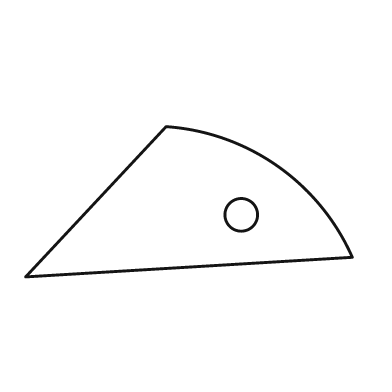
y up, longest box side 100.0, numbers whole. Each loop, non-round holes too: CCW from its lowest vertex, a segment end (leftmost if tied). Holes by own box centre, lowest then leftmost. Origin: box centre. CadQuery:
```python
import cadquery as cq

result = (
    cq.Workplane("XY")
    .moveTo(-50.0, -23.0)
    .lineTo(50.0, -17.0)
    .threePointArc((27.0, 11.0), (-7.0, 23.0))
    .close()
    .moveTo(16.0, -4.0)
    .circle(5.0)
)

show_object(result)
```